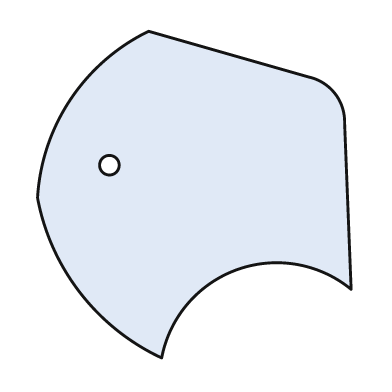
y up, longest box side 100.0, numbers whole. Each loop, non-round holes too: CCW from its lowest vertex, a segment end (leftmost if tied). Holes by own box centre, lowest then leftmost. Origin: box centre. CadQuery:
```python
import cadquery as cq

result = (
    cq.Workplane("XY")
    .moveTo(-10.0, -50.0)
    .threePointArc((13.0, -23.0), (48.0, -29.0))
    .lineTo(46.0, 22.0)
    .threePointArc((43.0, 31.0), (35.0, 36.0))
    .lineTo(-14.0, 50.0)
    .threePointArc((-38.0, 29.0), (-48.0, -1.0))
    .threePointArc((-35.0, -30.0), (-10.0, -50.0))
    .close()
    .moveTo(-26.0, 9.0)
    .circle(3.0)
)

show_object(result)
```